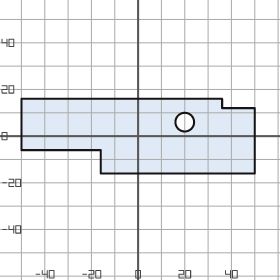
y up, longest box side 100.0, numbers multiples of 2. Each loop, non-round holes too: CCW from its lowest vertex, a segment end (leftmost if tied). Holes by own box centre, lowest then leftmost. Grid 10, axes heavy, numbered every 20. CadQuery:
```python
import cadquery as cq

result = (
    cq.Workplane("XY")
    .moveTo(-16.0, -16.0)
    .lineTo(50.0, -16.0)
    .lineTo(50.0, 12.0)
    .lineTo(36.0, 12.0)
    .lineTo(36.0, 16.0)
    .lineTo(-50.0, 16.0)
    .lineTo(-50.0, -6.0)
    .lineTo(-16.0, -6.0)
    .close()
    .moveTo(20.0, 6.0)
    .circle(4.0)
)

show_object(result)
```